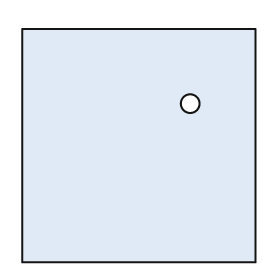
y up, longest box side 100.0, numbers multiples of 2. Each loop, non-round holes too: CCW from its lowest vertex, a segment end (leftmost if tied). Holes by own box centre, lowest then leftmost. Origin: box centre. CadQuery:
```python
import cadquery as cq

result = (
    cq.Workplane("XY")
    .moveTo(-50.0, -50.0)
    .lineTo(50.0, -50.0)
    .lineTo(50.0, 50.0)
    .lineTo(-50.0, 50.0)
    .close()
    .moveTo(22.0, 18.0)
    .circle(4.0)
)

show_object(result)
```